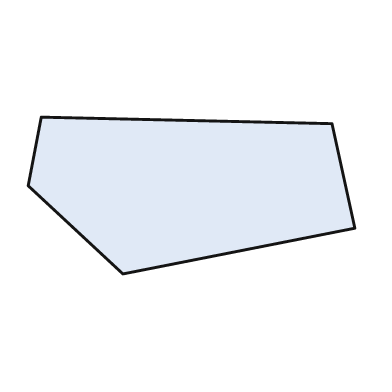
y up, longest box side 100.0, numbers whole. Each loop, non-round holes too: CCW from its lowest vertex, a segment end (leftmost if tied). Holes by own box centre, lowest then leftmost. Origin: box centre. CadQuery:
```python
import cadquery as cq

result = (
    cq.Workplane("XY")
    .moveTo(-21.0, -24.0)
    .lineTo(50.0, -10.0)
    .lineTo(43.0, 22.0)
    .lineTo(-46.0, 24.0)
    .lineTo(-50.0, 3.0)
    .close()
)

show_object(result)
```